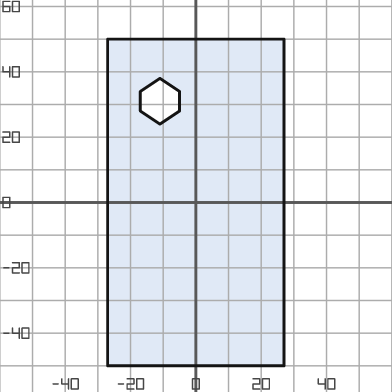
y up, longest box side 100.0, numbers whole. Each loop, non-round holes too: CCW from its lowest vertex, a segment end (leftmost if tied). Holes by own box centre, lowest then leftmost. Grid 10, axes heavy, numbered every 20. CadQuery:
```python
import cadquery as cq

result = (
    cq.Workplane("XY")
    .moveTo(-27.0, -50.0)
    .lineTo(27.0, -50.0)
    .lineTo(27.0, 50.0)
    .lineTo(-27.0, 50.0)
    .close()
    .moveTo(-11.0, 24.0)
    .lineTo(-5.0, 28.0)
    .lineTo(-5.0, 34.0)
    .lineTo(-11.0, 38.0)
    .lineTo(-17.0, 34.0)
    .lineTo(-17.0, 28.0)
    .close()
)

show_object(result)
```